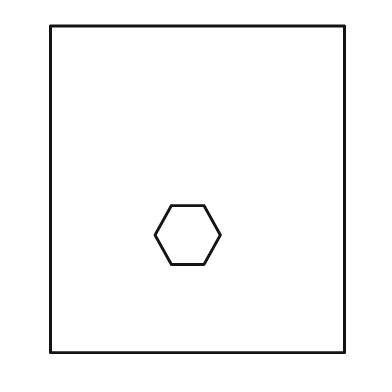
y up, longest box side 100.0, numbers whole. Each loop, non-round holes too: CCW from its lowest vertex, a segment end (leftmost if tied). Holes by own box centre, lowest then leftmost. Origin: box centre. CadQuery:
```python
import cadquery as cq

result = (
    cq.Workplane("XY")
    .moveTo(-45.0, -50.0)
    .lineTo(45.0, -50.0)
    .lineTo(45.0, 50.0)
    .lineTo(-45.0, 50.0)
    .close()
    .moveTo(-8.0, -23.0)
    .lineTo(2.0, -23.0)
    .lineTo(7.0, -14.0)
    .lineTo(2.0, -5.0)
    .lineTo(-8.0, -5.0)
    .lineTo(-13.0, -14.0)
    .close()
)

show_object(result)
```